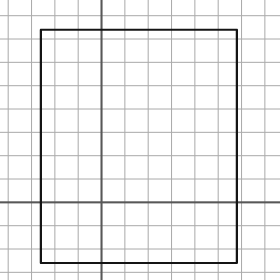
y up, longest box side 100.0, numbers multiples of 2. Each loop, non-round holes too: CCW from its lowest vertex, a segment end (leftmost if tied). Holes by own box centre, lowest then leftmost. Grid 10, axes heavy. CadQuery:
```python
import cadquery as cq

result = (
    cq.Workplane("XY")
    .moveTo(-26.0, -26.0)
    .lineTo(58.0, -26.0)
    .lineTo(58.0, 74.0)
    .lineTo(-26.0, 74.0)
    .close()
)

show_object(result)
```